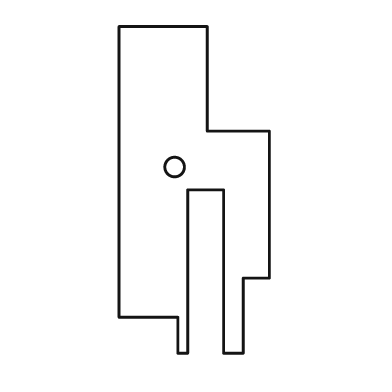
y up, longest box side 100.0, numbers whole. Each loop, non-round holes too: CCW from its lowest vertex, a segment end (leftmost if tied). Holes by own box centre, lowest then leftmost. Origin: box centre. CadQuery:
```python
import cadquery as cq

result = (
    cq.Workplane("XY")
    .moveTo(-5.0, -50.0)
    .lineTo(-2.0, -50.0)
    .lineTo(-2.0, 0.0)
    .lineTo(9.0, 0.0)
    .lineTo(9.0, -50.0)
    .lineTo(15.0, -50.0)
    .lineTo(15.0, -27.0)
    .lineTo(23.0, -27.0)
    .lineTo(23.0, 18.0)
    .lineTo(4.0, 18.0)
    .lineTo(4.0, 50.0)
    .lineTo(-23.0, 50.0)
    .lineTo(-23.0, -39.0)
    .lineTo(-5.0, -39.0)
    .close()
    .moveTo(-6.0, 7.0)
    .circle(3.0)
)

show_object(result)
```